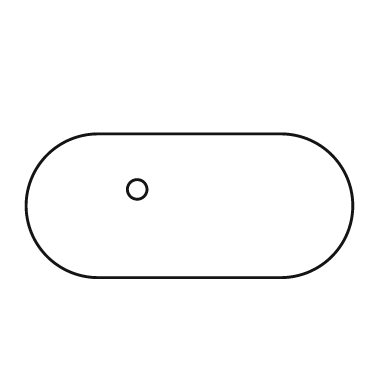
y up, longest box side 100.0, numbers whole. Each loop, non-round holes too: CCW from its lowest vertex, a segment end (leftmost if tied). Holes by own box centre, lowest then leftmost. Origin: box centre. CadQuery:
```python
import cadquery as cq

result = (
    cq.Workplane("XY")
    .moveTo(-28.0, -22.0)
    .lineTo(28.0, -22.0)
    .threePointArc((50.0, 0.0), (28.0, 22.0))
    .lineTo(-28.0, 22.0)
    .threePointArc((-50.0, 0.0), (-28.0, -22.0))
    .close()
    .moveTo(-16.0, 5.0)
    .circle(3.0)
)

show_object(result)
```